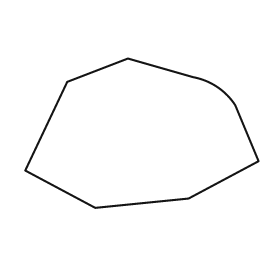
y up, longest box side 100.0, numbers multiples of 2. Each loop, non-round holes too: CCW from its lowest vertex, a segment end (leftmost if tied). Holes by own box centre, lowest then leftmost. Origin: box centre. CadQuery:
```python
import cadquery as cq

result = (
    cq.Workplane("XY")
    .moveTo(-20.0, -32.0)
    .lineTo(20.0, -28.0)
    .lineTo(50.0, -12.0)
    .lineTo(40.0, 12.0)
    .threePointArc((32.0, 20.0), (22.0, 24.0))
    .lineTo(-6.0, 32.0)
    .lineTo(-32.0, 22.0)
    .lineTo(-50.0, -16.0)
    .close()
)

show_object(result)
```